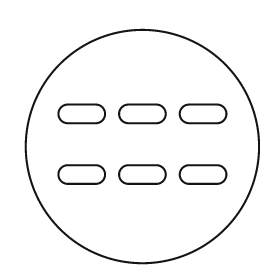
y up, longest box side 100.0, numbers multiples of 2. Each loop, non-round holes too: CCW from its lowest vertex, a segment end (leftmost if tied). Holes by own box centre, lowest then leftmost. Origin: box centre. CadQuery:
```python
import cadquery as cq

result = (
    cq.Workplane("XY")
    .moveTo(0.0, 0.0)
    .circle(50.0)
    .moveTo(-32.0, -16.0)
    .lineTo(-20.0, -16.0)
    .threePointArc((-16.0, -12.0), (-20.0, -8.0))
    .lineTo(-32.0, -8.0)
    .threePointArc((-36.0, -12.0), (-32.0, -16.0))
    .close()
    .moveTo(-6.0, -16.0)
    .lineTo(6.0, -16.0)
    .threePointArc((10.0, -12.0), (6.0, -8.0))
    .lineTo(-6.0, -8.0)
    .threePointArc((-10.0, -12.0), (-6.0, -16.0))
    .close()
    .moveTo(20.0, -16.0)
    .lineTo(32.0, -16.0)
    .threePointArc((36.0, -12.0), (32.0, -8.0))
    .lineTo(20.0, -8.0)
    .threePointArc((16.0, -12.0), (20.0, -16.0))
    .close()
    .moveTo(-32.0, 10.0)
    .lineTo(-20.0, 10.0)
    .threePointArc((-16.0, 14.0), (-20.0, 18.0))
    .lineTo(-32.0, 18.0)
    .threePointArc((-36.0, 14.0), (-32.0, 10.0))
    .close()
    .moveTo(-6.0, 10.0)
    .lineTo(6.0, 10.0)
    .threePointArc((10.0, 14.0), (6.0, 18.0))
    .lineTo(-6.0, 18.0)
    .threePointArc((-10.0, 14.0), (-6.0, 10.0))
    .close()
    .moveTo(20.0, 10.0)
    .lineTo(32.0, 10.0)
    .threePointArc((36.0, 14.0), (32.0, 18.0))
    .lineTo(20.0, 18.0)
    .threePointArc((16.0, 14.0), (20.0, 10.0))
    .close()
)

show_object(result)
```